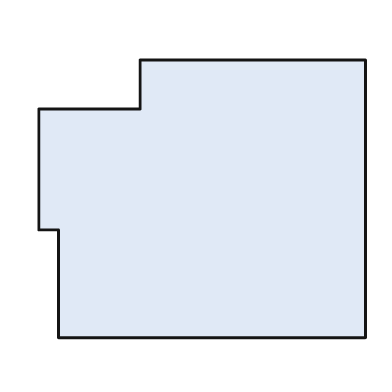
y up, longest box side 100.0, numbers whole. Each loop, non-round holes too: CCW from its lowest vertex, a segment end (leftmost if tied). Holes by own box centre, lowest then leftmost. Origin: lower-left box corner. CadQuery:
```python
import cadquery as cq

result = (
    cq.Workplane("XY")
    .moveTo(6.0, 0.0)
    .lineTo(100.0, 0.0)
    .lineTo(100.0, 85.0)
    .lineTo(31.0, 85.0)
    .lineTo(31.0, 70.0)
    .lineTo(0.0, 70.0)
    .lineTo(0.0, 33.0)
    .lineTo(6.0, 33.0)
    .close()
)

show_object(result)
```